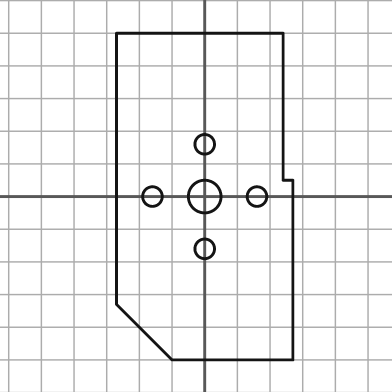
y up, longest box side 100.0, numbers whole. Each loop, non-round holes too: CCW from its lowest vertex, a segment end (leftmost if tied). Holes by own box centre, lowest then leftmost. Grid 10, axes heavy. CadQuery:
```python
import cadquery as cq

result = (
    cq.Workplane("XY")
    .moveTo(-10.0, -50.0)
    .lineTo(27.0, -50.0)
    .lineTo(27.0, 5.0)
    .lineTo(24.0, 5.0)
    .lineTo(24.0, 50.0)
    .lineTo(-27.0, 50.0)
    .lineTo(-27.0, -33.0)
    .close()
    .moveTo(0.0, -16.0)
    .circle(3.0)
    .moveTo(-16.0, 0.0)
    .circle(3.0)
    .moveTo(0.0, 0.0)
    .circle(5.0)
    .moveTo(16.0, 0.0)
    .circle(3.0)
    .moveTo(0.0, 16.0)
    .circle(3.0)
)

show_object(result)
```